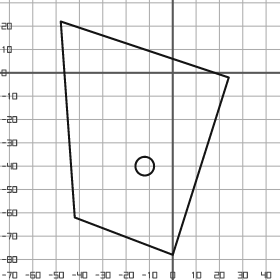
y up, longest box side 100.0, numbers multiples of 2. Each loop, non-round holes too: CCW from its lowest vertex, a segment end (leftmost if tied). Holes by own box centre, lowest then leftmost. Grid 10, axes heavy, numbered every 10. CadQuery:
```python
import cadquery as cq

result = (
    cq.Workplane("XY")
    .moveTo(0.0, -78.0)
    .lineTo(24.0, -2.0)
    .lineTo(-48.0, 22.0)
    .lineTo(-42.0, -62.0)
    .close()
    .moveTo(-12.0, -40.0)
    .circle(4.0)
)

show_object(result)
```